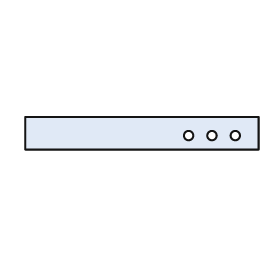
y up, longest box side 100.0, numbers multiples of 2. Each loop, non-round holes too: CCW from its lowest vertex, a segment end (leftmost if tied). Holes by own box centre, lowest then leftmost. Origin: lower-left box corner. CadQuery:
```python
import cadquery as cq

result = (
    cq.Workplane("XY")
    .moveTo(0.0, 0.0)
    .lineTo(100.0, 0.0)
    .lineTo(100.0, 14.0)
    .lineTo(0.0, 14.0)
    .close()
    .moveTo(70.0, 6.0)
    .circle(2.0)
    .moveTo(80.0, 6.0)
    .circle(2.0)
    .moveTo(90.0, 6.0)
    .circle(2.0)
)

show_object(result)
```